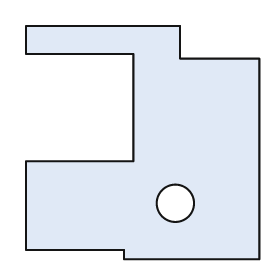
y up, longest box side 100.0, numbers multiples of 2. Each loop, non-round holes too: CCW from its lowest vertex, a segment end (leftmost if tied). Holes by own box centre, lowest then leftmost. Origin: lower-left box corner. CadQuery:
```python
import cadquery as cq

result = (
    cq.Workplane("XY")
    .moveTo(42.0, 0.0)
    .lineTo(100.0, 0.0)
    .lineTo(100.0, 86.0)
    .lineTo(66.0, 86.0)
    .lineTo(66.0, 100.0)
    .lineTo(0.0, 100.0)
    .lineTo(0.0, 88.0)
    .lineTo(46.0, 88.0)
    .lineTo(46.0, 42.0)
    .lineTo(0.0, 42.0)
    .lineTo(0.0, 4.0)
    .lineTo(42.0, 4.0)
    .close()
    .moveTo(64.0, 24.0)
    .circle(8.0)
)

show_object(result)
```